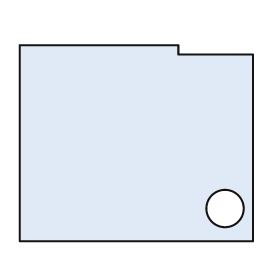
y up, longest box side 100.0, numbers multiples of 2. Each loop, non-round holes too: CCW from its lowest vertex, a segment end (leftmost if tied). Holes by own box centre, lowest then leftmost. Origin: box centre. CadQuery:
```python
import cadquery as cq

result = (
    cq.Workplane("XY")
    .moveTo(-50.0, -42.0)
    .lineTo(50.0, -42.0)
    .lineTo(50.0, 38.0)
    .lineTo(18.0, 38.0)
    .lineTo(18.0, 42.0)
    .lineTo(-50.0, 42.0)
    .close()
    .moveTo(38.0, -28.0)
    .circle(8.0)
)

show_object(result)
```